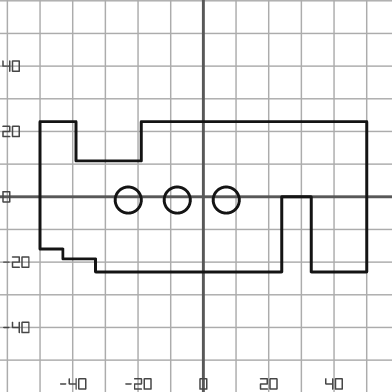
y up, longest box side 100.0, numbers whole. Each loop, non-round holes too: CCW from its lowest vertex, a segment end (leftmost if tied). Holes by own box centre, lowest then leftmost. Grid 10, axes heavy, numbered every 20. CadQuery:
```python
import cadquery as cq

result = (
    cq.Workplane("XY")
    .moveTo(-33.0, -23.0)
    .lineTo(24.0, -23.0)
    .lineTo(24.0, 0.0)
    .lineTo(33.0, 0.0)
    .lineTo(33.0, -23.0)
    .lineTo(50.0, -23.0)
    .lineTo(50.0, 23.0)
    .lineTo(-19.0, 23.0)
    .lineTo(-19.0, 11.0)
    .lineTo(-39.0, 11.0)
    .lineTo(-39.0, 23.0)
    .lineTo(-50.0, 23.0)
    .lineTo(-50.0, -16.0)
    .lineTo(-43.0, -16.0)
    .lineTo(-43.0, -19.0)
    .lineTo(-33.0, -19.0)
    .close()
    .moveTo(-23.0, -1.0)
    .circle(4.0)
    .moveTo(-8.0, -1.0)
    .circle(4.0)
    .moveTo(7.0, -1.0)
    .circle(4.0)
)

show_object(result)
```